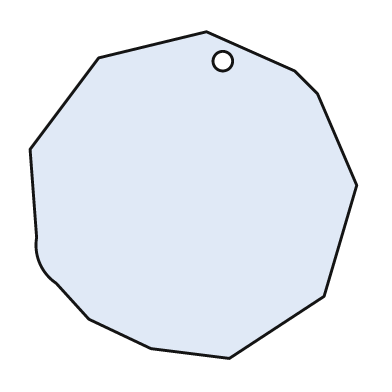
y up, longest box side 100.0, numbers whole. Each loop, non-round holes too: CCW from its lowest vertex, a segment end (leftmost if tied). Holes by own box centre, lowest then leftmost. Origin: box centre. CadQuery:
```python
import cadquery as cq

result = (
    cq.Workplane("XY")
    .moveTo(11.0, -50.0)
    .lineTo(40.0, -31.0)
    .lineTo(50.0, 3.0)
    .lineTo(38.0, 31.0)
    .lineTo(31.0, 38.0)
    .lineTo(4.0, 50.0)
    .lineTo(-29.0, 42.0)
    .lineTo(-50.0, 14.0)
    .lineTo(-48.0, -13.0)
    .threePointArc((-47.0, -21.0), (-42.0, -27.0))
    .lineTo(-32.0, -38.0)
    .lineTo(-13.0, -47.0)
    .close()
    .moveTo(9.0, 41.0)
    .circle(3.0)
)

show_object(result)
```